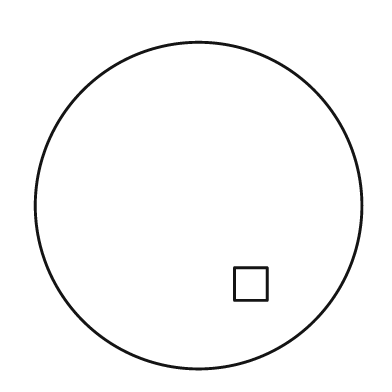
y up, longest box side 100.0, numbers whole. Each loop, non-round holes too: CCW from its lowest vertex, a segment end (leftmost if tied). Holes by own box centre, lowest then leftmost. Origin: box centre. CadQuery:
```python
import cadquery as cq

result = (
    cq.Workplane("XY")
    .moveTo(0.0, 0.0)
    .circle(50.0)
    .moveTo(11.0, -29.0)
    .lineTo(21.0, -29.0)
    .lineTo(21.0, -19.0)
    .lineTo(11.0, -19.0)
    .close()
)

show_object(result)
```